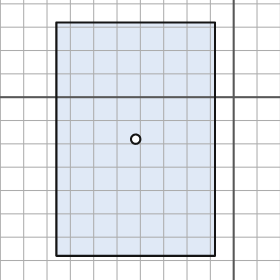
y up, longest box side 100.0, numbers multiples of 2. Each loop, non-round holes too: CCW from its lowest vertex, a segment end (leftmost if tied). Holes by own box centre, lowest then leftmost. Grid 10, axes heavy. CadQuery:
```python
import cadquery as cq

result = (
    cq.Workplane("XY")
    .moveTo(-76.0, -68.0)
    .lineTo(-8.0, -68.0)
    .lineTo(-8.0, 32.0)
    .lineTo(-76.0, 32.0)
    .close()
    .moveTo(-42.0, -18.0)
    .circle(2.0)
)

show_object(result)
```